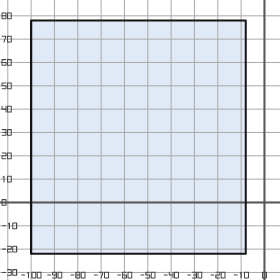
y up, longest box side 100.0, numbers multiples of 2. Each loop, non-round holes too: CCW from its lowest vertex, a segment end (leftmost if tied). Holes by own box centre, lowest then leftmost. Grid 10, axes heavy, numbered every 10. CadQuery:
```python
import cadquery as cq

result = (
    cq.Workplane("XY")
    .moveTo(-100.0, -22.0)
    .lineTo(-8.0, -22.0)
    .lineTo(-8.0, 78.0)
    .lineTo(-100.0, 78.0)
    .close()
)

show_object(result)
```